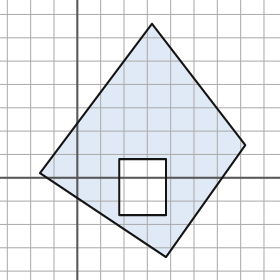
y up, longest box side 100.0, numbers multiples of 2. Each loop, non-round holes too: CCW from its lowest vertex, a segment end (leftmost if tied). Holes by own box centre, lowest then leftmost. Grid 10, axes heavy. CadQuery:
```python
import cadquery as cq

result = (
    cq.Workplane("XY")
    .moveTo(38.0, -34.0)
    .lineTo(72.0, 14.0)
    .lineTo(32.0, 66.0)
    .lineTo(-16.0, 2.0)
    .close()
    .moveTo(18.0, -16.0)
    .lineTo(38.0, -16.0)
    .lineTo(38.0, 8.0)
    .lineTo(18.0, 8.0)
    .close()
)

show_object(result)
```